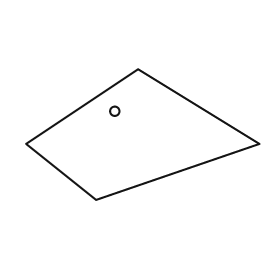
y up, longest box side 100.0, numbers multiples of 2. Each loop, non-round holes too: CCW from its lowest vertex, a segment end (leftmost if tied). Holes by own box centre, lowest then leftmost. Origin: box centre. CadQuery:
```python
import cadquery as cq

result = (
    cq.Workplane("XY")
    .moveTo(-20.0, -28.0)
    .lineTo(50.0, -4.0)
    .lineTo(-2.0, 28.0)
    .lineTo(-50.0, -4.0)
    .close()
    .moveTo(-12.0, 10.0)
    .circle(2.0)
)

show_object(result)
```